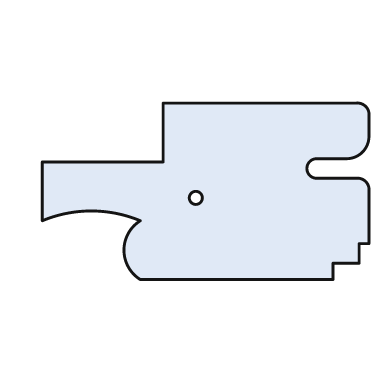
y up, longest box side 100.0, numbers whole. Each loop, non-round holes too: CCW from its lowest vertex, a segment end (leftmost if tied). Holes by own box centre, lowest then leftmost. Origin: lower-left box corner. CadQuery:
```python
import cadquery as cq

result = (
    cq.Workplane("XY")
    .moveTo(30.0, 0.0)
    .lineTo(89.0, 0.0)
    .lineTo(89.0, 5.0)
    .lineTo(97.0, 5.0)
    .lineTo(97.0, 11.0)
    .lineTo(100.0, 11.0)
    .lineTo(100.0, 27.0)
    .threePointArc((99.0, 30.0), (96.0, 31.0))
    .lineTo(84.0, 31.0)
    .threePointArc((81.0, 34.0), (84.0, 37.0))
    .lineTo(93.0, 37.0)
    .threePointArc((98.0, 39.0), (100.0, 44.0))
    .lineTo(100.0, 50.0)
    .threePointArc((99.0, 53.0), (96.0, 54.0))
    .lineTo(37.0, 54.0)
    .lineTo(37.0, 36.0)
    .lineTo(0.0, 36.0)
    .lineTo(0.0, 18.0)
    .threePointArc((15.0, 21.0), (30.0, 18.0))
    .threePointArc((25.0, 9.0), (30.0, 0.0))
    .close()
    .moveTo(47.0, 25.0)
    .circle(2.0)
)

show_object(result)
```